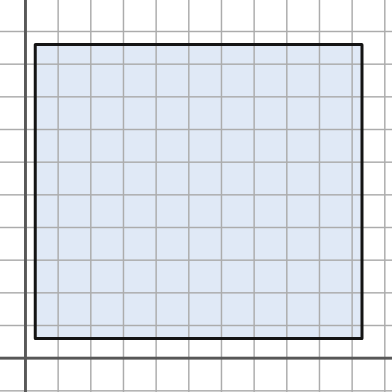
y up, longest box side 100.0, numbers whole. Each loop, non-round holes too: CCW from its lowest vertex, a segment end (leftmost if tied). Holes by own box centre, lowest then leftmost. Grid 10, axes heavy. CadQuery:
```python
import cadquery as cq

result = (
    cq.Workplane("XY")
    .moveTo(3.0, 6.0)
    .lineTo(103.0, 6.0)
    .lineTo(103.0, 96.0)
    .lineTo(3.0, 96.0)
    .close()
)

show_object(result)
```